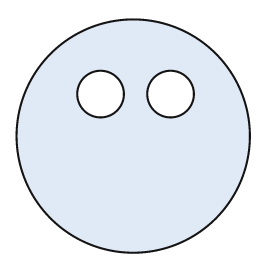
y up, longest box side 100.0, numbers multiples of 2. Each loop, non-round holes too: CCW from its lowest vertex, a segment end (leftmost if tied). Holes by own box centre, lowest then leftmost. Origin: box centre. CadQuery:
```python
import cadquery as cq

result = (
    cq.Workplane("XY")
    .moveTo(0.0, 0.0)
    .circle(50.0)
    .moveTo(-14.0, 18.0)
    .circle(10.0)
    .moveTo(16.0, 18.0)
    .circle(10.0)
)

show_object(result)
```